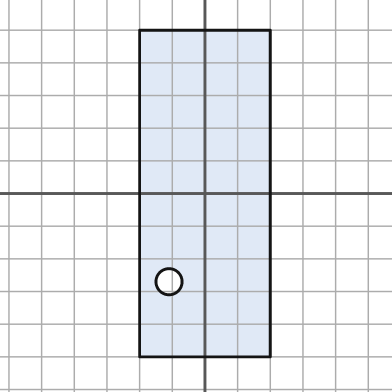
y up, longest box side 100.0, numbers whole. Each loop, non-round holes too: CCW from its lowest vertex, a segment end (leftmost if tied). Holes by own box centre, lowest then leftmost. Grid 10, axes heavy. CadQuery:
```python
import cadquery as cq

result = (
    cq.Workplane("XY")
    .moveTo(-20.0, -50.0)
    .lineTo(20.0, -50.0)
    .lineTo(20.0, 50.0)
    .lineTo(-20.0, 50.0)
    .close()
    .moveTo(-11.0, -27.0)
    .circle(4.0)
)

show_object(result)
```